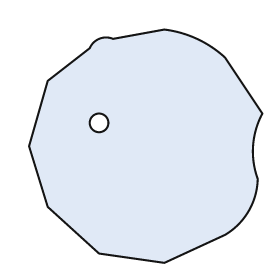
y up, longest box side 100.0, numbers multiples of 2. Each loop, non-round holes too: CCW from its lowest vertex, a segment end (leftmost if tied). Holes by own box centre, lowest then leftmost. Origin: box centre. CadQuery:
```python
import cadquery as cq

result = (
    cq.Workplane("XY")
    .moveTo(8.0, -50.0)
    .lineTo(34.0, -38.0)
    .threePointArc((44.0, -28.0), (48.0, -14.0))
    .threePointArc((46.0, 0.0), (50.0, 14.0))
    .lineTo(34.0, 38.0)
    .threePointArc((22.0, 46.0), (8.0, 50.0))
    .lineTo(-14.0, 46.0)
    .threePointArc((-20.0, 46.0), (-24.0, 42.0))
    .lineTo(-42.0, 28.0)
    .lineTo(-50.0, 0.0)
    .lineTo(-42.0, -26.0)
    .lineTo(-20.0, -46.0)
    .close()
    .moveTo(-20.0, 10.0)
    .circle(4.0)
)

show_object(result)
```